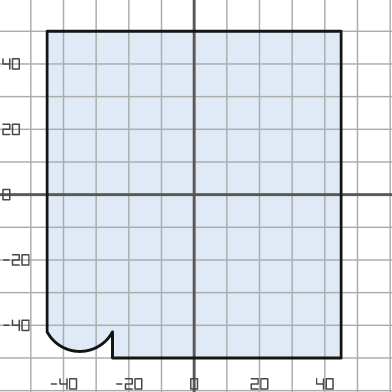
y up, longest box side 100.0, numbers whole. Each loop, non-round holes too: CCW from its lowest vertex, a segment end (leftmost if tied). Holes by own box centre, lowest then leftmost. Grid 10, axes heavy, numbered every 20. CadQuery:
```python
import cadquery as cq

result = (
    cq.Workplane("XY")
    .moveTo(-25.0, -50.0)
    .lineTo(45.0, -50.0)
    .lineTo(45.0, 50.0)
    .lineTo(-45.0, 50.0)
    .lineTo(-45.0, -42.0)
    .threePointArc((-35.0, -48.0), (-25.0, -42.0))
    .close()
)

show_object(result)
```